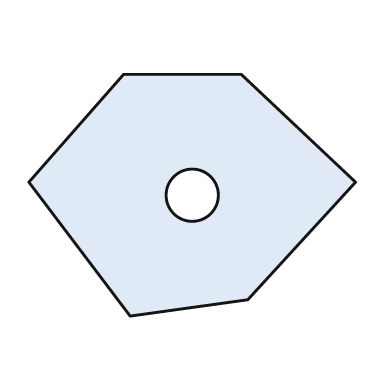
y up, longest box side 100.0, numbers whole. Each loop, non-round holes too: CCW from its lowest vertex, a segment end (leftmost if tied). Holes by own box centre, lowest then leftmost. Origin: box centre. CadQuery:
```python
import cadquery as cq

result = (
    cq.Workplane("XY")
    .moveTo(-19.0, -37.0)
    .lineTo(17.0, -32.0)
    .lineTo(50.0, 4.0)
    .lineTo(15.0, 37.0)
    .lineTo(-21.0, 37.0)
    .lineTo(-50.0, 4.0)
    .close()
    .moveTo(0.0, 0.0)
    .circle(8.0)
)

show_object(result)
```